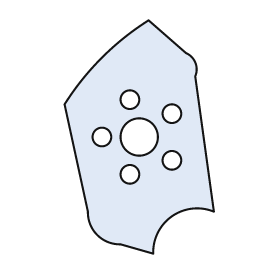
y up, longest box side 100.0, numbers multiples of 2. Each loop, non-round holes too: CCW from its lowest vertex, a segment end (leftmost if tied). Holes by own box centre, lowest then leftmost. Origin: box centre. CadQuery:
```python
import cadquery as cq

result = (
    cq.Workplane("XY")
    .moveTo(6.0, -50.0)
    .threePointArc((14.0, -34.0), (32.0, -32.0))
    .lineTo(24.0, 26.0)
    .threePointArc((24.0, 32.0), (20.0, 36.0))
    .lineTo(4.0, 50.0)
    .threePointArc((-16.0, 34.0), (-32.0, 14.0))
    .lineTo(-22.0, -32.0)
    .threePointArc((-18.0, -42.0), (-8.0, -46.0))
    .close()
    .moveTo(-4.0, -16.0)
    .circle(4.0)
    .moveTo(14.0, -10.0)
    .circle(4.0)
    .moveTo(-16.0, 0.0)
    .circle(4.0)
    .moveTo(0.0, 0.0)
    .circle(8.0)
    .moveTo(14.0, 10.0)
    .circle(4.0)
    .moveTo(-4.0, 16.0)
    .circle(4.0)
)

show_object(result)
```